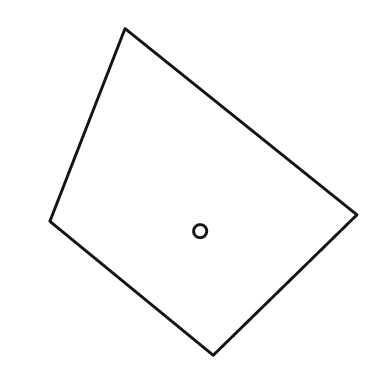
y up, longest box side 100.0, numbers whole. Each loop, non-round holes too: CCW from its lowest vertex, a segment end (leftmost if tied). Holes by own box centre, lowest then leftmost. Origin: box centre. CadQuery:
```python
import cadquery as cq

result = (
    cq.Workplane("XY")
    .moveTo(3.0, -50.0)
    .lineTo(47.0, -7.0)
    .lineTo(-24.0, 50.0)
    .lineTo(-47.0, -9.0)
    .close()
    .moveTo(-1.0, -12.0)
    .circle(2.0)
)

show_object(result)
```